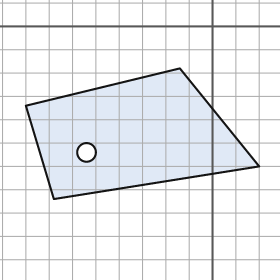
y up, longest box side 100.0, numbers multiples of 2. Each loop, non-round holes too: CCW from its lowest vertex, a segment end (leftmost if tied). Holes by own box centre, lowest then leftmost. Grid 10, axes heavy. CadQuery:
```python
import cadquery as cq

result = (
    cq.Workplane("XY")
    .moveTo(-68.0, -74.0)
    .lineTo(20.0, -60.0)
    .lineTo(-14.0, -18.0)
    .lineTo(-80.0, -34.0)
    .close()
    .moveTo(-54.0, -54.0)
    .circle(4.0)
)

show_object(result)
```